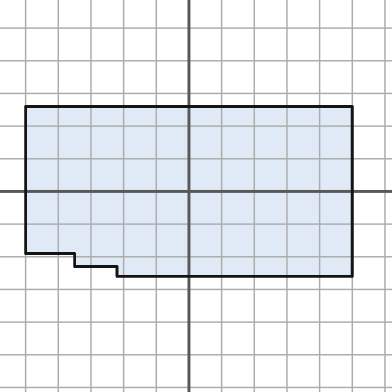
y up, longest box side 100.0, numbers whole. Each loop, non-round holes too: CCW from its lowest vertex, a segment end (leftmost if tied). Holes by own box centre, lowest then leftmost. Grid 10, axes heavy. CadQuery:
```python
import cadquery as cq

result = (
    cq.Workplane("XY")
    .moveTo(-22.0, -26.0)
    .lineTo(50.0, -26.0)
    .lineTo(50.0, 26.0)
    .lineTo(-50.0, 26.0)
    .lineTo(-50.0, -19.0)
    .lineTo(-35.0, -19.0)
    .lineTo(-35.0, -23.0)
    .lineTo(-22.0, -23.0)
    .close()
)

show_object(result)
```